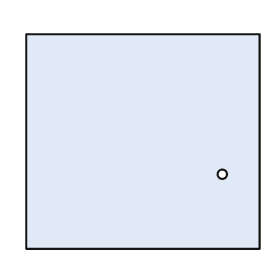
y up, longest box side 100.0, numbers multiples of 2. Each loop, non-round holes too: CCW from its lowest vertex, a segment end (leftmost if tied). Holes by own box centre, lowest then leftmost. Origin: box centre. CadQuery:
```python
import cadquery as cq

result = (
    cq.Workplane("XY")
    .moveTo(-50.0, -46.0)
    .lineTo(50.0, -46.0)
    .lineTo(50.0, 46.0)
    .lineTo(-50.0, 46.0)
    .close()
    .moveTo(34.0, -14.0)
    .circle(2.0)
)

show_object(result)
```